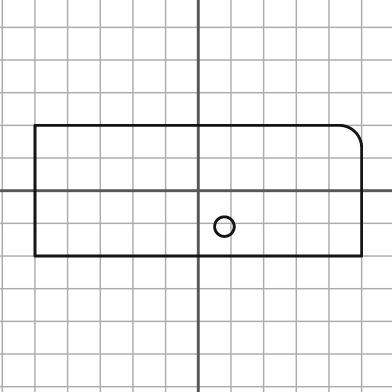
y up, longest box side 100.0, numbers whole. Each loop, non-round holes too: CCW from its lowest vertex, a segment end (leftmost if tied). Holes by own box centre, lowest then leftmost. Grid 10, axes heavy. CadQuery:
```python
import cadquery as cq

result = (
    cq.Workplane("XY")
    .moveTo(-50.0, -20.0)
    .lineTo(50.0, -20.0)
    .lineTo(50.0, 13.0)
    .threePointArc((48.0, 18.0), (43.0, 20.0))
    .lineTo(-50.0, 20.0)
    .close()
    .moveTo(8.0, -11.0)
    .circle(3.0)
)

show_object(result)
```